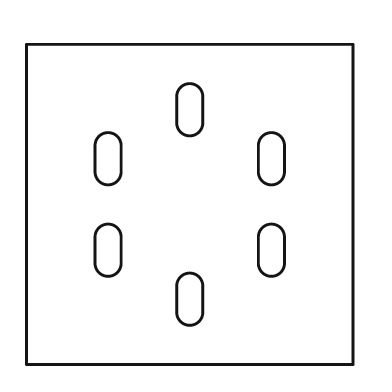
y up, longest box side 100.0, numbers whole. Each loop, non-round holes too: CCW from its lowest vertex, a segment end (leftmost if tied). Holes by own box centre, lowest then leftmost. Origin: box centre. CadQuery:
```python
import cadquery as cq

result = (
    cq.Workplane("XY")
    .moveTo(-50.0, -49.0)
    .lineTo(50.0, -49.0)
    .lineTo(50.0, 49.0)
    .lineTo(-50.0, 49.0)
    .close()
    .moveTo(-4.0, -33.0)
    .threePointArc((0.0, -37.0), (4.0, -33.0))
    .lineTo(4.0, -25.0)
    .threePointArc((0.0, -21.0), (-4.0, -25.0))
    .close()
    .moveTo(-29.0, -18.0)
    .threePointArc((-25.0, -22.0), (-21.0, -18.0))
    .lineTo(-21.0, -10.0)
    .threePointArc((-25.0, -6.0), (-29.0, -10.0))
    .close()
    .moveTo(21.0, -18.0)
    .threePointArc((25.0, -22.0), (29.0, -18.0))
    .lineTo(29.0, -10.0)
    .threePointArc((25.0, -6.0), (21.0, -10.0))
    .close()
    .moveTo(-29.0, 10.0)
    .threePointArc((-25.0, 6.0), (-21.0, 10.0))
    .lineTo(-21.0, 18.0)
    .threePointArc((-25.0, 22.0), (-29.0, 18.0))
    .close()
    .moveTo(21.0, 10.0)
    .threePointArc((25.0, 6.0), (29.0, 10.0))
    .lineTo(29.0, 18.0)
    .threePointArc((25.0, 22.0), (21.0, 18.0))
    .close()
    .moveTo(-4.0, 25.0)
    .threePointArc((0.0, 21.0), (4.0, 25.0))
    .lineTo(4.0, 33.0)
    .threePointArc((0.0, 37.0), (-4.0, 33.0))
    .close()
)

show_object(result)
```